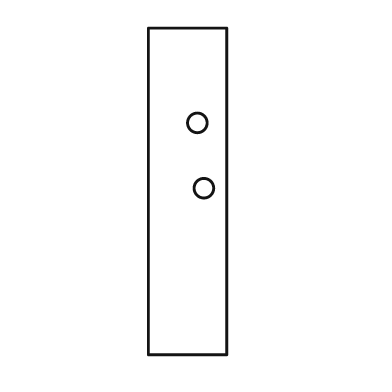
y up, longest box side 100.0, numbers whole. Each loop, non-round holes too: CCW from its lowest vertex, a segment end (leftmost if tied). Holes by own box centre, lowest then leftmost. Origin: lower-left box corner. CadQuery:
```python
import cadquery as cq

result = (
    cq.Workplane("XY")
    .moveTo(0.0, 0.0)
    .lineTo(24.0, 0.0)
    .lineTo(24.0, 100.0)
    .lineTo(0.0, 100.0)
    .close()
    .moveTo(17.0, 51.0)
    .circle(3.0)
    .moveTo(15.0, 71.0)
    .circle(3.0)
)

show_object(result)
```